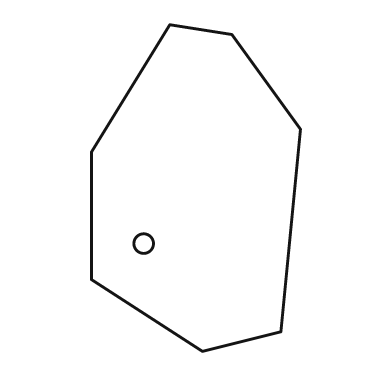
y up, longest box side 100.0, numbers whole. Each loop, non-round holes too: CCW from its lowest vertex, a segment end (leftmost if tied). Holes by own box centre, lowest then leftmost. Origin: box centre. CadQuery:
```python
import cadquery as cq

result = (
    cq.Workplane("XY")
    .moveTo(2.0, -50.0)
    .lineTo(26.0, -44.0)
    .lineTo(32.0, 18.0)
    .lineTo(11.0, 47.0)
    .lineTo(-8.0, 50.0)
    .lineTo(-32.0, 11.0)
    .lineTo(-32.0, -28.0)
    .close()
    .moveTo(-16.0, -17.0)
    .circle(3.0)
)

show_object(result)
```